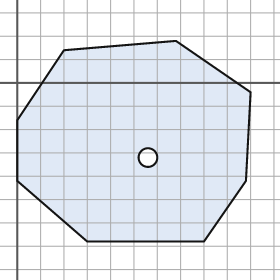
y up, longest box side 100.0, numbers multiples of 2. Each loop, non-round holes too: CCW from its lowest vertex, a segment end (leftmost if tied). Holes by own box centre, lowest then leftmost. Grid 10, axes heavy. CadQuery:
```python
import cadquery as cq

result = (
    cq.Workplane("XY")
    .moveTo(30.0, -68.0)
    .lineTo(80.0, -68.0)
    .lineTo(98.0, -42.0)
    .lineTo(100.0, -4.0)
    .lineTo(68.0, 18.0)
    .lineTo(20.0, 14.0)
    .lineTo(0.0, -16.0)
    .lineTo(0.0, -42.0)
    .close()
    .moveTo(56.0, -32.0)
    .circle(4.0)
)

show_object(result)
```